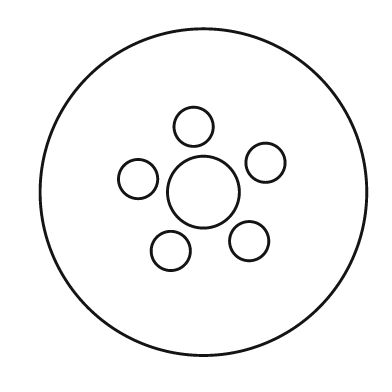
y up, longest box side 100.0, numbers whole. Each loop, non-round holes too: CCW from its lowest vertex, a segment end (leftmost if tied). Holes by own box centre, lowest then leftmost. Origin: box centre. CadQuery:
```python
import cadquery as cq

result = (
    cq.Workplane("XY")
    .moveTo(0.0, 0.0)
    .circle(50.0)
    .moveTo(-10.0, -18.0)
    .circle(6.0)
    .moveTo(14.0, -15.0)
    .circle(6.0)
    .moveTo(0.0, 0.0)
    .circle(11.0)
    .moveTo(-20.0, 4.0)
    .circle(6.0)
    .moveTo(19.0, 9.0)
    .circle(6.0)
    .moveTo(-3.0, 20.0)
    .circle(6.0)
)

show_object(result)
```